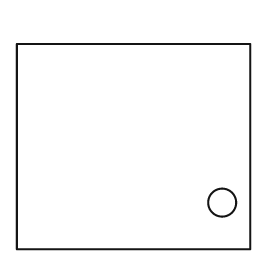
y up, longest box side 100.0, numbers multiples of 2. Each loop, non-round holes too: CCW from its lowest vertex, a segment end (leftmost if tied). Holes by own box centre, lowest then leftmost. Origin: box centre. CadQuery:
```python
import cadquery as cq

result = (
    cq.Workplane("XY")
    .moveTo(-50.0, -44.0)
    .lineTo(50.0, -44.0)
    .lineTo(50.0, 44.0)
    .lineTo(-50.0, 44.0)
    .close()
    .moveTo(38.0, -24.0)
    .circle(6.0)
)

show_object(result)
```